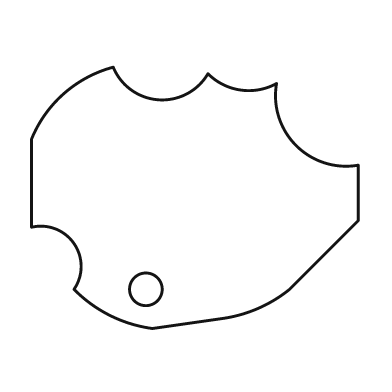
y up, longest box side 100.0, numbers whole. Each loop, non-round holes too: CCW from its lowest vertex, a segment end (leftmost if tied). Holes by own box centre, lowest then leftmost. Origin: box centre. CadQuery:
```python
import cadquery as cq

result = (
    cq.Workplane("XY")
    .moveTo(-13.0, -40.0)
    .lineTo(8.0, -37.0)
    .threePointArc((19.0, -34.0), (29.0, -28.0))
    .lineTo(50.0, -7.0)
    .lineTo(50.0, 10.0)
    .threePointArc((31.0, 16.0), (25.0, 35.0))
    .threePointArc((14.0, 33.0), (4.0, 38.0))
    .threePointArc((-11.0, 30.0), (-25.0, 40.0))
    .threePointArc((-40.0, 32.0), (-50.0, 18.0))
    .lineTo(-50.0, -9.0)
    .threePointArc((-37.0, -14.0), (-37.0, -28.0))
    .threePointArc((-26.0, -36.0), (-13.0, -40.0))
    .close()
    .moveTo(-15.0, -28.0)
    .circle(5.0)
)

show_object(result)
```